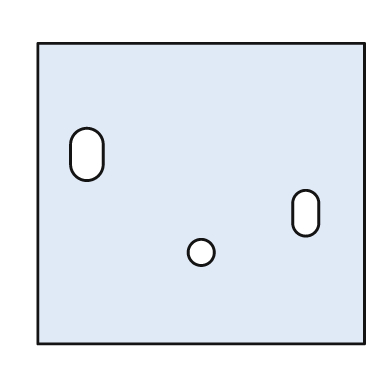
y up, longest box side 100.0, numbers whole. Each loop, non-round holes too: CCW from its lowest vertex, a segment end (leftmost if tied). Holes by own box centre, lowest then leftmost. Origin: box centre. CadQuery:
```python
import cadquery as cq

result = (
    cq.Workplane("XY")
    .moveTo(-50.0, -46.0)
    .lineTo(50.0, -46.0)
    .lineTo(50.0, 46.0)
    .lineTo(-50.0, 46.0)
    .close()
    .moveTo(0.0, -18.0)
    .circle(4.0)
    .moveTo(28.0, -9.0)
    .threePointArc((32.0, -13.0), (36.0, -9.0))
    .lineTo(36.0, -3.0)
    .threePointArc((32.0, 1.0), (28.0, -3.0))
    .close()
    .moveTo(-40.0, 9.0)
    .threePointArc((-35.0, 4.0), (-30.0, 9.0))
    .lineTo(-30.0, 15.0)
    .threePointArc((-35.0, 20.0), (-40.0, 15.0))
    .close()
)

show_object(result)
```